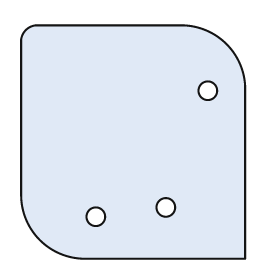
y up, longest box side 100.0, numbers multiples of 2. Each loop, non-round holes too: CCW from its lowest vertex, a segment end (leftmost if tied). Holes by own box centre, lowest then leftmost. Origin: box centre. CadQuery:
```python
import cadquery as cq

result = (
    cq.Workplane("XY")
    .moveTo(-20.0, -50.0)
    .lineTo(48.0, -50.0)
    .lineTo(48.0, 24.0)
    .threePointArc((40.0, 42.0), (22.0, 50.0))
    .lineTo(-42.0, 50.0)
    .threePointArc((-46.0, 48.0), (-48.0, 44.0))
    .lineTo(-48.0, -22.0)
    .threePointArc((-40.0, -42.0), (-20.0, -50.0))
    .close()
    .moveTo(-16.0, -32.0)
    .circle(4.0)
    .moveTo(14.0, -28.0)
    .circle(4.0)
    .moveTo(32.0, 22.0)
    .circle(4.0)
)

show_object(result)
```